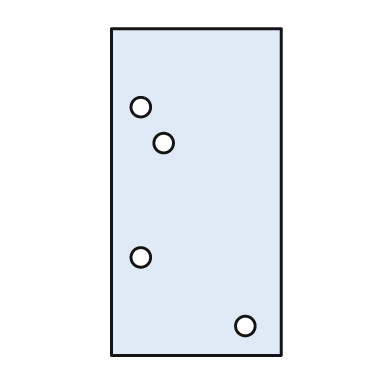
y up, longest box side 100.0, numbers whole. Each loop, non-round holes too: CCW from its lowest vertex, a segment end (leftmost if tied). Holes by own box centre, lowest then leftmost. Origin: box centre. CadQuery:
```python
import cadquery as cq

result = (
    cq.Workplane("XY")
    .moveTo(-26.0, -50.0)
    .lineTo(26.0, -50.0)
    .lineTo(26.0, 50.0)
    .lineTo(-26.0, 50.0)
    .close()
    .moveTo(15.0, -41.0)
    .circle(3.0)
    .moveTo(-17.0, -20.0)
    .circle(3.0)
    .moveTo(-10.0, 15.0)
    .circle(3.0)
    .moveTo(-17.0, 26.0)
    .circle(3.0)
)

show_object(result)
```